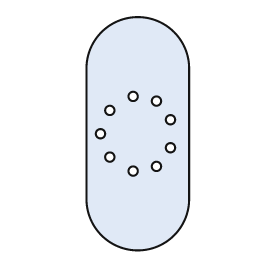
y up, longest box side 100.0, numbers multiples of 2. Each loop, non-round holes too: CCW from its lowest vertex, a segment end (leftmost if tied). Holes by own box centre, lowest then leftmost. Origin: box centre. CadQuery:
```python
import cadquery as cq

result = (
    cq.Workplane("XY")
    .moveTo(-22.0, -28.0)
    .threePointArc((0.0, -50.0), (22.0, -28.0))
    .lineTo(22.0, 28.0)
    .threePointArc((0.0, 50.0), (-22.0, 28.0))
    .close()
    .moveTo(-2.0, -16.0)
    .circle(2.0)
    .moveTo(8.0, -14.0)
    .circle(2.0)
    .moveTo(-12.0, -10.0)
    .circle(2.0)
    .moveTo(14.0, -6.0)
    .circle(2.0)
    .moveTo(-16.0, 0.0)
    .circle(2.0)
    .moveTo(14.0, 6.0)
    .circle(2.0)
    .moveTo(-12.0, 10.0)
    .circle(2.0)
    .moveTo(8.0, 14.0)
    .circle(2.0)
    .moveTo(-2.0, 16.0)
    .circle(2.0)
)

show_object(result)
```